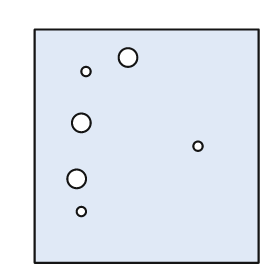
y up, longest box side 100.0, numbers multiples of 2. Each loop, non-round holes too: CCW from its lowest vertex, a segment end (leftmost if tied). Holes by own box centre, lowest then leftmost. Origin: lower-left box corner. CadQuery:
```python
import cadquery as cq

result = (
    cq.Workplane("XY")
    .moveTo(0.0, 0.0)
    .lineTo(96.0, 0.0)
    .lineTo(96.0, 100.0)
    .lineTo(0.0, 100.0)
    .close()
    .moveTo(20.0, 22.0)
    .circle(2.0)
    .moveTo(18.0, 36.0)
    .circle(4.0)
    .moveTo(70.0, 50.0)
    .circle(2.0)
    .moveTo(20.0, 60.0)
    .circle(4.0)
    .moveTo(22.0, 82.0)
    .circle(2.0)
    .moveTo(40.0, 88.0)
    .circle(4.0)
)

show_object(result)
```